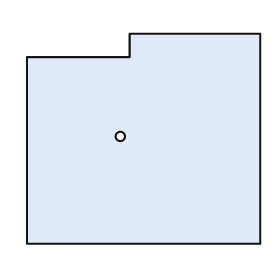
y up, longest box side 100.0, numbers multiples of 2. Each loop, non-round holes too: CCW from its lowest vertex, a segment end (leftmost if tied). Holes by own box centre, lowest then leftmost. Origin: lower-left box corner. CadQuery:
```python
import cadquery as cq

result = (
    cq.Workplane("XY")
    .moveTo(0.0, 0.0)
    .lineTo(100.0, 0.0)
    .lineTo(100.0, 90.0)
    .lineTo(44.0, 90.0)
    .lineTo(44.0, 80.0)
    .lineTo(0.0, 80.0)
    .close()
    .moveTo(40.0, 46.0)
    .circle(2.0)
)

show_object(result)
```